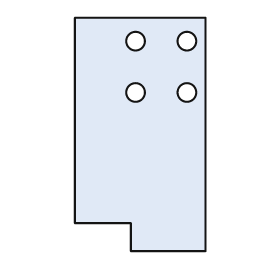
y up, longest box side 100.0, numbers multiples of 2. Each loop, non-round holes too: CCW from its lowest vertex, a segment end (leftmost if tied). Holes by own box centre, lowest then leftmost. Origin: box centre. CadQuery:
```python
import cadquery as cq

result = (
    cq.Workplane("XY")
    .moveTo(-4.0, -50.0)
    .lineTo(28.0, -50.0)
    .lineTo(28.0, 50.0)
    .lineTo(-28.0, 50.0)
    .lineTo(-28.0, -38.0)
    .lineTo(-4.0, -38.0)
    .close()
    .moveTo(-2.0, 18.0)
    .circle(4.0)
    .moveTo(20.0, 18.0)
    .circle(4.0)
    .moveTo(-2.0, 40.0)
    .circle(4.0)
    .moveTo(20.0, 40.0)
    .circle(4.0)
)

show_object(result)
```